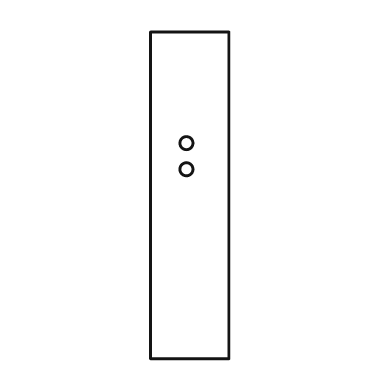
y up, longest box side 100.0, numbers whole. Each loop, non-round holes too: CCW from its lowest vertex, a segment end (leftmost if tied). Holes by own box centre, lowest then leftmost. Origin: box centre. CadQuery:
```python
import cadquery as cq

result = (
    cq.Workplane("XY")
    .moveTo(-12.0, -50.0)
    .lineTo(12.0, -50.0)
    .lineTo(12.0, 50.0)
    .lineTo(-12.0, 50.0)
    .close()
    .moveTo(-1.0, 8.0)
    .circle(2.0)
    .moveTo(-1.0, 16.0)
    .circle(2.0)
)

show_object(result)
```